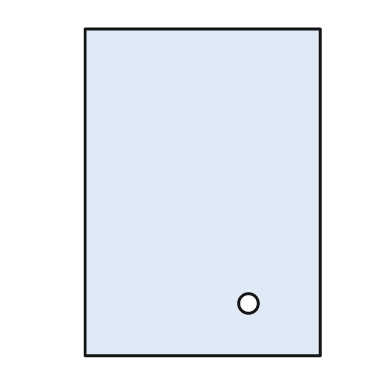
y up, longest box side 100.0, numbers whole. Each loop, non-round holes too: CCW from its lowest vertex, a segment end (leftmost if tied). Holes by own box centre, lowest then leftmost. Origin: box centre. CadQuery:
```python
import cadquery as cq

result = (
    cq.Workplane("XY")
    .moveTo(-36.0, -50.0)
    .lineTo(36.0, -50.0)
    .lineTo(36.0, 50.0)
    .lineTo(-36.0, 50.0)
    .close()
    .moveTo(14.0, -34.0)
    .circle(3.0)
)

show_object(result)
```